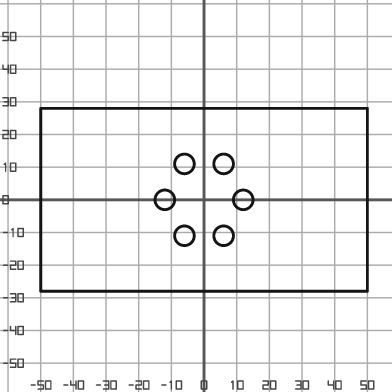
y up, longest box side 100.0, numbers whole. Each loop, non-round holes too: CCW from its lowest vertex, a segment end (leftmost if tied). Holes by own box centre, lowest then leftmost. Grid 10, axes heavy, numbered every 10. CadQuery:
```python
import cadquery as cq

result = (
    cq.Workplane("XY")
    .moveTo(-50.0, -28.0)
    .lineTo(50.0, -28.0)
    .lineTo(50.0, 28.0)
    .lineTo(-50.0, 28.0)
    .close()
    .moveTo(-6.0, -11.0)
    .circle(3.0)
    .moveTo(6.0, -11.0)
    .circle(3.0)
    .moveTo(-12.0, 0.0)
    .circle(3.0)
    .moveTo(12.0, 0.0)
    .circle(3.0)
    .moveTo(-6.0, 11.0)
    .circle(3.0)
    .moveTo(6.0, 11.0)
    .circle(3.0)
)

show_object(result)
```